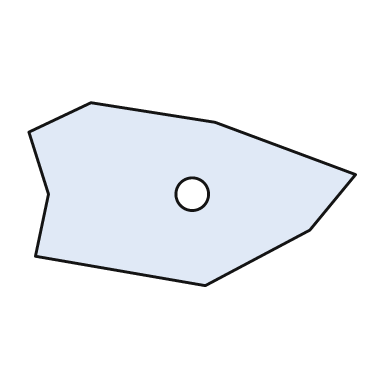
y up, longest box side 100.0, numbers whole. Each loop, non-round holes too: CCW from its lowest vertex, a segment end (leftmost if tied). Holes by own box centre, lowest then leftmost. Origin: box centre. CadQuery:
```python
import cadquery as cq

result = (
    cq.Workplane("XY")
    .moveTo(4.0, -28.0)
    .lineTo(36.0, -11.0)
    .lineTo(50.0, 6.0)
    .lineTo(7.0, 22.0)
    .lineTo(-31.0, 28.0)
    .lineTo(-50.0, 19.0)
    .lineTo(-44.0, 0.0)
    .lineTo(-48.0, -19.0)
    .close()
    .moveTo(0.0, 0.0)
    .circle(5.0)
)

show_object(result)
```